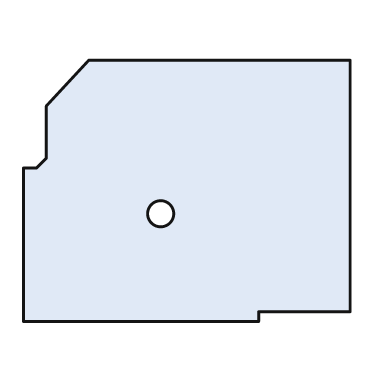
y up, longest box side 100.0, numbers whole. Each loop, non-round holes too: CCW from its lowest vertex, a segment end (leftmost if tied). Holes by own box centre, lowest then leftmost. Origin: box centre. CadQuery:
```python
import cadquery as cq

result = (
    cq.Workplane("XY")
    .moveTo(-50.0, -40.0)
    .lineTo(22.0, -40.0)
    .lineTo(22.0, -37.0)
    .lineTo(50.0, -37.0)
    .lineTo(50.0, 40.0)
    .lineTo(-30.0, 40.0)
    .lineTo(-43.0, 26.0)
    .lineTo(-43.0, 10.0)
    .lineTo(-46.0, 7.0)
    .lineTo(-50.0, 7.0)
    .close()
    .moveTo(-8.0, -7.0)
    .circle(4.0)
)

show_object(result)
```